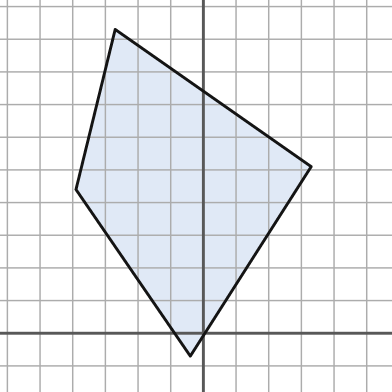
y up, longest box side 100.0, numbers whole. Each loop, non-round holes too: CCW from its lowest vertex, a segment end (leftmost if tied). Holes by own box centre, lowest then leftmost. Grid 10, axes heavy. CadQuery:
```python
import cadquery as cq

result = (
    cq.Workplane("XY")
    .moveTo(-4.0, -7.0)
    .lineTo(33.0, 51.0)
    .lineTo(-27.0, 93.0)
    .lineTo(-39.0, 44.0)
    .close()
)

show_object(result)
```